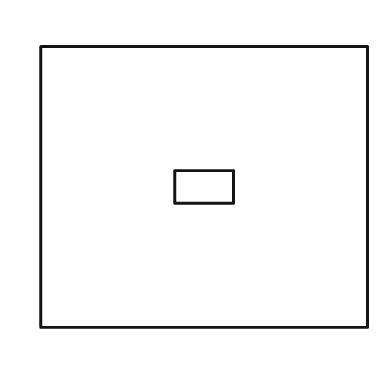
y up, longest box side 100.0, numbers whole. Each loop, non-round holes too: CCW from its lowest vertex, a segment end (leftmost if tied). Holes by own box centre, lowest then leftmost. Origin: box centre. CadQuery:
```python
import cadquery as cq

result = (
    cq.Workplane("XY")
    .moveTo(-50.0, -43.0)
    .lineTo(50.0, -43.0)
    .lineTo(50.0, 43.0)
    .lineTo(-50.0, 43.0)
    .close()
    .moveTo(-9.0, -5.0)
    .lineTo(9.0, -5.0)
    .lineTo(9.0, 5.0)
    .lineTo(-9.0, 5.0)
    .close()
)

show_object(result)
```